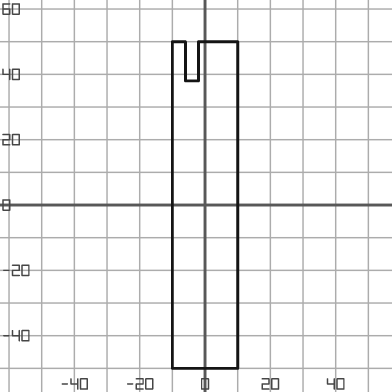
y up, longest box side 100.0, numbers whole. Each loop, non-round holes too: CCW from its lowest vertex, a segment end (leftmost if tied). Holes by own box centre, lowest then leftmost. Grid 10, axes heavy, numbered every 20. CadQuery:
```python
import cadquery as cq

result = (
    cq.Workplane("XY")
    .moveTo(-10.0, -50.0)
    .lineTo(10.0, -50.0)
    .lineTo(10.0, 50.0)
    .lineTo(-2.0, 50.0)
    .lineTo(-2.0, 38.0)
    .lineTo(-6.0, 38.0)
    .lineTo(-6.0, 50.0)
    .lineTo(-10.0, 50.0)
    .close()
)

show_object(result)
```